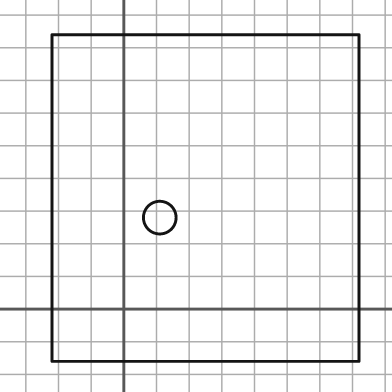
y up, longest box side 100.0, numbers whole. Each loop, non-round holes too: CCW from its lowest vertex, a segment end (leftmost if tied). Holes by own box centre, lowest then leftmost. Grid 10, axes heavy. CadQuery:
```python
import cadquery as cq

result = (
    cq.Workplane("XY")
    .moveTo(-22.0, -16.0)
    .lineTo(72.0, -16.0)
    .lineTo(72.0, 84.0)
    .lineTo(-22.0, 84.0)
    .close()
    .moveTo(11.0, 28.0)
    .circle(5.0)
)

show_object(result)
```